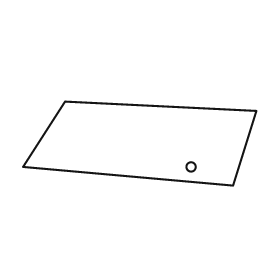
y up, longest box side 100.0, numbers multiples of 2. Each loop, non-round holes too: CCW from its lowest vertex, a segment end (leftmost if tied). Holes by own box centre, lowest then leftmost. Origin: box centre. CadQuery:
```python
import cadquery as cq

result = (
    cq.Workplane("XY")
    .moveTo(40.0, -18.0)
    .lineTo(50.0, 14.0)
    .lineTo(-32.0, 18.0)
    .lineTo(-50.0, -10.0)
    .close()
    .moveTo(22.0, -10.0)
    .circle(2.0)
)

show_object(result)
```